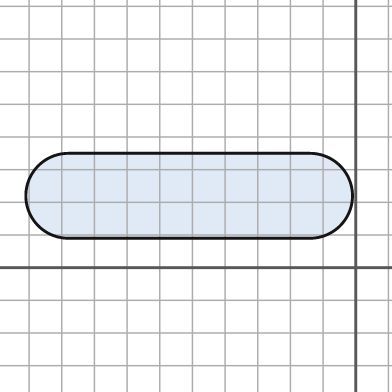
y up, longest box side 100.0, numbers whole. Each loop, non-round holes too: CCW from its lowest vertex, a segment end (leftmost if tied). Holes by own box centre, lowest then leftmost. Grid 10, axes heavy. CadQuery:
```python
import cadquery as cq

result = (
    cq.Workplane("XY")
    .moveTo(-88.0, 9.0)
    .lineTo(-14.0, 9.0)
    .threePointArc((-1.0, 22.0), (-14.0, 35.0))
    .lineTo(-88.0, 35.0)
    .threePointArc((-101.0, 22.0), (-88.0, 9.0))
    .close()
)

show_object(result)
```